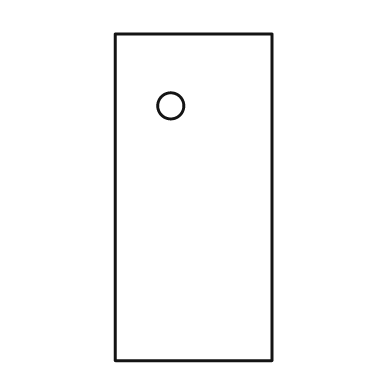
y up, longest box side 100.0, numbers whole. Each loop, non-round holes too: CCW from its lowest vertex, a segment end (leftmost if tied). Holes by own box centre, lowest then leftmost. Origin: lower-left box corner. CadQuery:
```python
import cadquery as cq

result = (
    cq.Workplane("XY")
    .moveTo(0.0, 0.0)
    .lineTo(48.0, 0.0)
    .lineTo(48.0, 100.0)
    .lineTo(0.0, 100.0)
    .close()
    .moveTo(17.0, 78.0)
    .circle(4.0)
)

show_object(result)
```